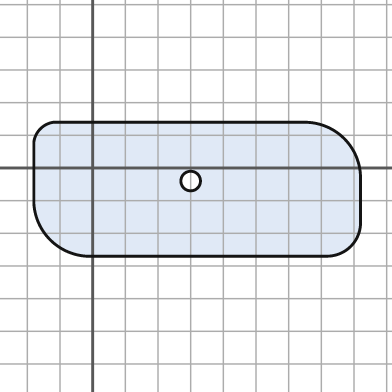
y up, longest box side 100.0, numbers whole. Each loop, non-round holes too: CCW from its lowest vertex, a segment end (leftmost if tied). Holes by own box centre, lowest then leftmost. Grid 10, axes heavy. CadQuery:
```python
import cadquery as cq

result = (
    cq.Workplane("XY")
    .moveTo(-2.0, -27.0)
    .lineTo(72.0, -27.0)
    .threePointArc((79.0, -24.0), (82.0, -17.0))
    .lineTo(82.0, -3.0)
    .threePointArc((77.0, 9.0), (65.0, 14.0))
    .lineTo(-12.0, 14.0)
    .threePointArc((-16.0, 12.0), (-18.0, 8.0))
    .lineTo(-18.0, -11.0)
    .threePointArc((-13.0, -22.0), (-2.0, -27.0))
    .close()
    .moveTo(30.0, -4.0)
    .circle(3.0)
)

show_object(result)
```